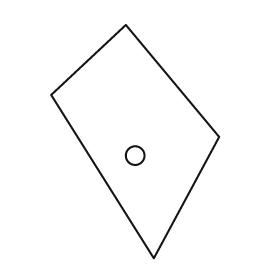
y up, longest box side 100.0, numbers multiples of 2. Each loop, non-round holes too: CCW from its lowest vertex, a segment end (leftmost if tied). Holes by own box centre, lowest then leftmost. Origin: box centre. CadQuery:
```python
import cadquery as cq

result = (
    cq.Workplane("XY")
    .moveTo(8.0, -50.0)
    .lineTo(36.0, 2.0)
    .lineTo(-4.0, 50.0)
    .lineTo(-36.0, 20.0)
    .close()
    .moveTo(0.0, -6.0)
    .circle(4.0)
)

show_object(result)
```